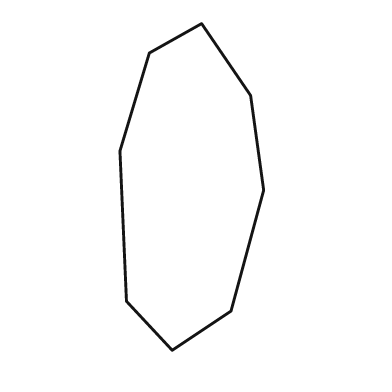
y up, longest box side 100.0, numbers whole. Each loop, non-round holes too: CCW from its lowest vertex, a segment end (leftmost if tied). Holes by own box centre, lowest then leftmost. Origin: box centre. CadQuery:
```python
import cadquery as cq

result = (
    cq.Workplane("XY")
    .moveTo(-6.0, -50.0)
    .lineTo(12.0, -38.0)
    .lineTo(22.0, -1.0)
    .lineTo(18.0, 28.0)
    .lineTo(3.0, 50.0)
    .lineTo(-13.0, 41.0)
    .lineTo(-22.0, 11.0)
    .lineTo(-20.0, -35.0)
    .close()
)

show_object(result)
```